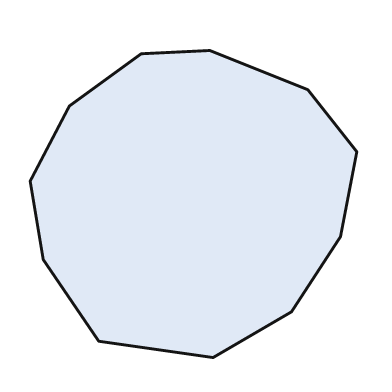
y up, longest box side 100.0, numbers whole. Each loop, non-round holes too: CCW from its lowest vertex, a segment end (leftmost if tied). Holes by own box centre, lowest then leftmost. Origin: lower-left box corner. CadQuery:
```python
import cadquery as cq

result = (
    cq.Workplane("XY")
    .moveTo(56.0, 0.0)
    .lineTo(80.0, 14.0)
    .lineTo(95.0, 37.0)
    .lineTo(100.0, 63.0)
    .lineTo(85.0, 82.0)
    .lineTo(55.0, 94.0)
    .lineTo(34.0, 93.0)
    .lineTo(12.0, 77.0)
    .lineTo(0.0, 54.0)
    .lineTo(4.0, 30.0)
    .lineTo(21.0, 5.0)
    .close()
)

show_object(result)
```